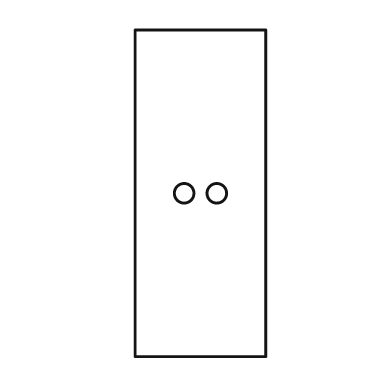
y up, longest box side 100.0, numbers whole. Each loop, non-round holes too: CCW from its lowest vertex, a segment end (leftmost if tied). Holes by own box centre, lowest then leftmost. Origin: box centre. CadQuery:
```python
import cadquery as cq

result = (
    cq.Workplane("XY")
    .moveTo(-20.0, -50.0)
    .lineTo(20.0, -50.0)
    .lineTo(20.0, 50.0)
    .lineTo(-20.0, 50.0)
    .close()
    .moveTo(-5.0, 0.0)
    .circle(3.0)
    .moveTo(5.0, 0.0)
    .circle(3.0)
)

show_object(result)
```